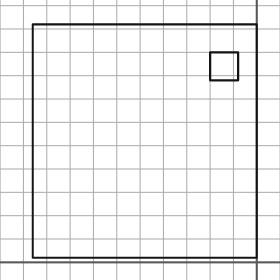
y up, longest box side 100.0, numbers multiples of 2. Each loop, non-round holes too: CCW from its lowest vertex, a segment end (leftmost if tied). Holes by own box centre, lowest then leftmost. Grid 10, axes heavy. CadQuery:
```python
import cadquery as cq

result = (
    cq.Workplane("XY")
    .moveTo(-96.0, 2.0)
    .lineTo(0.0, 2.0)
    .lineTo(0.0, 102.0)
    .lineTo(-96.0, 102.0)
    .close()
    .moveTo(-20.0, 78.0)
    .lineTo(-8.0, 78.0)
    .lineTo(-8.0, 90.0)
    .lineTo(-20.0, 90.0)
    .close()
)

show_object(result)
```